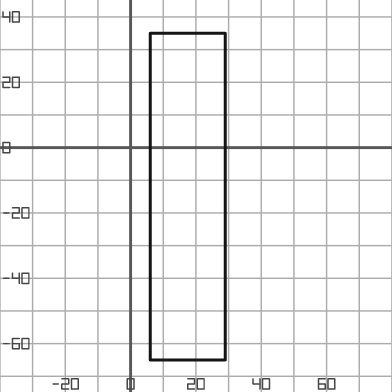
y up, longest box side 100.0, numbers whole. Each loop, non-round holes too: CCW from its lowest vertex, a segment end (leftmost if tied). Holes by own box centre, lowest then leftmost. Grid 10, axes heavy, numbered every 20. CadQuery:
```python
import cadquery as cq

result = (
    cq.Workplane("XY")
    .moveTo(6.0, -65.0)
    .lineTo(29.0, -65.0)
    .lineTo(29.0, 35.0)
    .lineTo(6.0, 35.0)
    .close()
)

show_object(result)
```